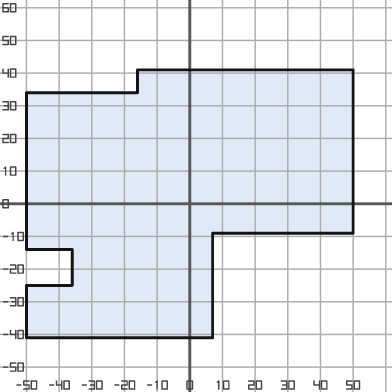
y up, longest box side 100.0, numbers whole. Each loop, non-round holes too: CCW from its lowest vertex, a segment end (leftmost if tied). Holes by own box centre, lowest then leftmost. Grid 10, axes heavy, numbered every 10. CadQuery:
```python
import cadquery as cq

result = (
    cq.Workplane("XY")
    .moveTo(-50.0, -41.0)
    .lineTo(7.0, -41.0)
    .lineTo(7.0, -9.0)
    .lineTo(50.0, -9.0)
    .lineTo(50.0, 41.0)
    .lineTo(-16.0, 41.0)
    .lineTo(-16.0, 34.0)
    .lineTo(-50.0, 34.0)
    .lineTo(-50.0, -14.0)
    .lineTo(-36.0, -14.0)
    .lineTo(-36.0, -25.0)
    .lineTo(-50.0, -25.0)
    .close()
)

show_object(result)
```